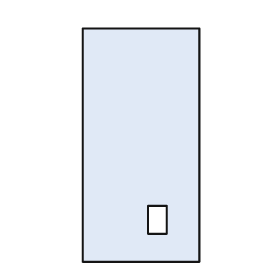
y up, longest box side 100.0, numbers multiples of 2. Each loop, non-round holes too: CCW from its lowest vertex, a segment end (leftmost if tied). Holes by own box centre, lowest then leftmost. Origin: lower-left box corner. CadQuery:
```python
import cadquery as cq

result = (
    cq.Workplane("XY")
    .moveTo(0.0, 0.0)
    .lineTo(50.0, 0.0)
    .lineTo(50.0, 100.0)
    .lineTo(0.0, 100.0)
    .close()
    .moveTo(28.0, 12.0)
    .lineTo(36.0, 12.0)
    .lineTo(36.0, 24.0)
    .lineTo(28.0, 24.0)
    .close()
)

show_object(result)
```